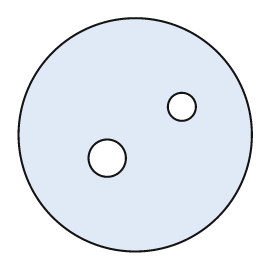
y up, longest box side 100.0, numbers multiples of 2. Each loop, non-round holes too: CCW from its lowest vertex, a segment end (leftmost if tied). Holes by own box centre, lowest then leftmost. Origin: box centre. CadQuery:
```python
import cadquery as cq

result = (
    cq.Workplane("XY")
    .moveTo(0.0, 0.0)
    .circle(50.0)
    .moveTo(-12.0, -10.0)
    .circle(8.0)
    .moveTo(20.0, 12.0)
    .circle(6.0)
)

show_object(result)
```